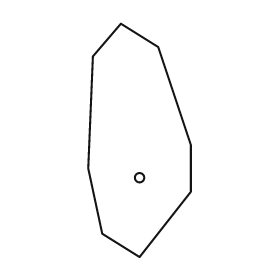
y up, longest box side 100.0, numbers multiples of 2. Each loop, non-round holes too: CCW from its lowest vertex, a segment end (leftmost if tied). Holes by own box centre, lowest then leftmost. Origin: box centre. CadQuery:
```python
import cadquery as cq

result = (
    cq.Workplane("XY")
    .moveTo(0.0, -50.0)
    .lineTo(22.0, -22.0)
    .lineTo(22.0, -2.0)
    .lineTo(8.0, 40.0)
    .lineTo(-8.0, 50.0)
    .lineTo(-20.0, 36.0)
    .lineTo(-22.0, -12.0)
    .lineTo(-16.0, -40.0)
    .close()
    .moveTo(0.0, -16.0)
    .circle(2.0)
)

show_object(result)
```